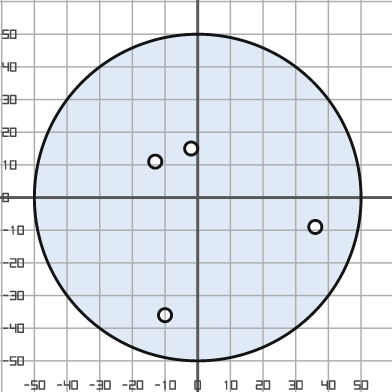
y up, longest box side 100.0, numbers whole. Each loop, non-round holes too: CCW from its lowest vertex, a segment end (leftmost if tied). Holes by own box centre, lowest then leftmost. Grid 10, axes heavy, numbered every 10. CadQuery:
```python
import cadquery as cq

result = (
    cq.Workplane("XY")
    .moveTo(0.0, 0.0)
    .circle(50.0)
    .moveTo(-10.0, -36.0)
    .circle(2.0)
    .moveTo(36.0, -9.0)
    .circle(2.0)
    .moveTo(-13.0, 11.0)
    .circle(2.0)
    .moveTo(-2.0, 15.0)
    .circle(2.0)
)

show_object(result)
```